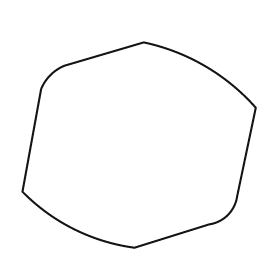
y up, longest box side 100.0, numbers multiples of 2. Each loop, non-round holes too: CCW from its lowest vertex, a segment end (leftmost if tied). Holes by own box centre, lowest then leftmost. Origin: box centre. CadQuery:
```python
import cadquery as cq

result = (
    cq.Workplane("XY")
    .moveTo(-2.0, -44.0)
    .lineTo(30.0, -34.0)
    .threePointArc((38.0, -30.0), (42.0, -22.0))
    .lineTo(50.0, 16.0)
    .threePointArc((28.0, 34.0), (2.0, 44.0))
    .lineTo(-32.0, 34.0)
    .threePointArc((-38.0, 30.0), (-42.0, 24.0))
    .lineTo(-50.0, -20.0)
    .threePointArc((-28.0, -36.0), (-2.0, -44.0))
    .close()
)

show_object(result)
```